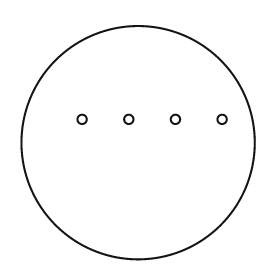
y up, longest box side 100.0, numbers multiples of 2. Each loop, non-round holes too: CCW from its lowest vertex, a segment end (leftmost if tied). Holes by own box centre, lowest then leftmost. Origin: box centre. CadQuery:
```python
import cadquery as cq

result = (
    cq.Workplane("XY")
    .moveTo(0.0, 0.0)
    .circle(50.0)
    .moveTo(-24.0, 10.0)
    .circle(2.0)
    .moveTo(-4.0, 10.0)
    .circle(2.0)
    .moveTo(16.0, 10.0)
    .circle(2.0)
    .moveTo(36.0, 10.0)
    .circle(2.0)
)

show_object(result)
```